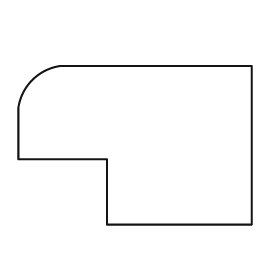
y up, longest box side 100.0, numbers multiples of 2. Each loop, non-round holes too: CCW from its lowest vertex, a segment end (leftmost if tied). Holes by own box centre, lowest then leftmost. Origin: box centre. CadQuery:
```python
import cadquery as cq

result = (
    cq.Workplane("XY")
    .moveTo(-12.0, -34.0)
    .lineTo(50.0, -34.0)
    .lineTo(50.0, 34.0)
    .lineTo(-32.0, 34.0)
    .threePointArc((-44.0, 28.0), (-50.0, 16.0))
    .lineTo(-50.0, -6.0)
    .lineTo(-12.0, -6.0)
    .close()
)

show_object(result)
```